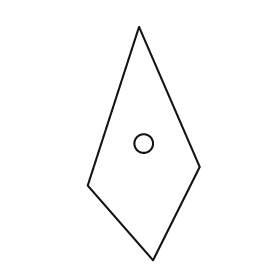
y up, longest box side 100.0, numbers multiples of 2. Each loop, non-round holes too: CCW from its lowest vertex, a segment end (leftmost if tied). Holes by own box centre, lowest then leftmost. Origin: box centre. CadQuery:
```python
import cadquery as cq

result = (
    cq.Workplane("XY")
    .moveTo(4.0, -50.0)
    .lineTo(24.0, -10.0)
    .lineTo(-2.0, 50.0)
    .lineTo(-24.0, -18.0)
    .close()
    .moveTo(0.0, 0.0)
    .circle(4.0)
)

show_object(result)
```